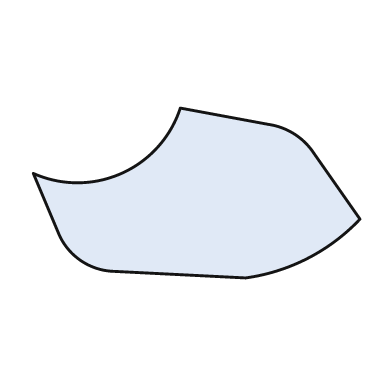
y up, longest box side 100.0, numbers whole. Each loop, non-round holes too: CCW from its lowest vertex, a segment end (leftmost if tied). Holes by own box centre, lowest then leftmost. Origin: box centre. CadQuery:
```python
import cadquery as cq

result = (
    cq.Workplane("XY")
    .moveTo(15.0, -26.0)
    .threePointArc((34.0, -20.0), (50.0, -8.0))
    .lineTo(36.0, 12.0)
    .threePointArc((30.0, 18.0), (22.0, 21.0))
    .lineTo(-5.0, 26.0)
    .threePointArc((-23.0, 6.0), (-50.0, 6.0))
    .lineTo(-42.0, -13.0)
    .threePointArc((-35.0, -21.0), (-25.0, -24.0))
    .close()
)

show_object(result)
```